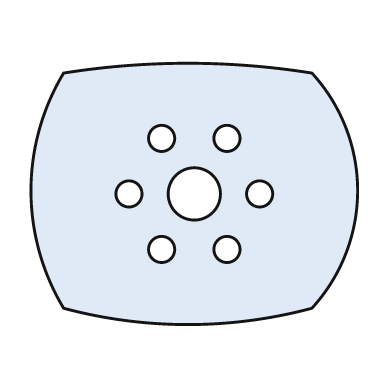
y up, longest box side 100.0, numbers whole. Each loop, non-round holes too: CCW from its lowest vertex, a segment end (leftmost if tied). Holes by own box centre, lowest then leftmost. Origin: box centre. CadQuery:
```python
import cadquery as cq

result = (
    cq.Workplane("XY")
    .moveTo(-40.0, -35.0)
    .threePointArc((-2.0, -40.0), (36.0, -35.0))
    .threePointArc((50.0, 1.0), (36.0, 37.0))
    .threePointArc((-2.0, 40.0), (-40.0, 37.0))
    .threePointArc((-50.0, 1.0), (-40.0, -35.0))
    .close()
    .moveTo(-10.0, -17.0)
    .circle(4.0)
    .moveTo(10.0, -17.0)
    .circle(4.0)
    .moveTo(-20.0, 0.0)
    .circle(4.0)
    .moveTo(0.0, 0.0)
    .circle(8.0)
    .moveTo(20.0, 0.0)
    .circle(4.0)
    .moveTo(-10.0, 17.0)
    .circle(4.0)
    .moveTo(10.0, 17.0)
    .circle(4.0)
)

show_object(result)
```